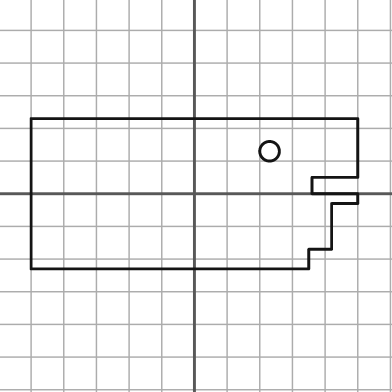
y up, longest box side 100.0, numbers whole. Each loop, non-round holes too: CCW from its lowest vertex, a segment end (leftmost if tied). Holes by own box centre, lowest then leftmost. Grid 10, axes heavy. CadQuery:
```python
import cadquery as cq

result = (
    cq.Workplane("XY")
    .moveTo(-50.0, -23.0)
    .lineTo(35.0, -23.0)
    .lineTo(35.0, -17.0)
    .lineTo(42.0, -17.0)
    .lineTo(42.0, -3.0)
    .lineTo(50.0, -3.0)
    .lineTo(50.0, 0.0)
    .lineTo(36.0, 0.0)
    .lineTo(36.0, 5.0)
    .lineTo(50.0, 5.0)
    .lineTo(50.0, 23.0)
    .lineTo(-50.0, 23.0)
    .close()
    .moveTo(23.0, 13.0)
    .circle(3.0)
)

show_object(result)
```